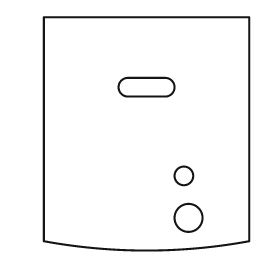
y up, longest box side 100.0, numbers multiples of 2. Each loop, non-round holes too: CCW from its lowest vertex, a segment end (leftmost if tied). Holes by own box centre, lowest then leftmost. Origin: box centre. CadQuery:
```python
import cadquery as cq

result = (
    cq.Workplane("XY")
    .moveTo(-44.0, -46.0)
    .threePointArc((0.0, -50.0), (44.0, -46.0))
    .lineTo(44.0, 50.0)
    .lineTo(-44.0, 50.0)
    .close()
    .moveTo(18.0, -36.0)
    .circle(6.0)
    .moveTo(16.0, -18.0)
    .circle(4.0)
    .moveTo(-8.0, 16.0)
    .lineTo(8.0, 16.0)
    .threePointArc((12.0, 20.0), (8.0, 24.0))
    .lineTo(-8.0, 24.0)
    .threePointArc((-12.0, 20.0), (-8.0, 16.0))
    .close()
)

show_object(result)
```